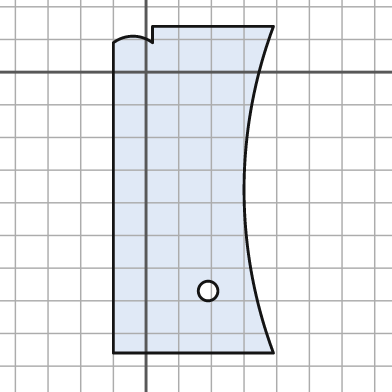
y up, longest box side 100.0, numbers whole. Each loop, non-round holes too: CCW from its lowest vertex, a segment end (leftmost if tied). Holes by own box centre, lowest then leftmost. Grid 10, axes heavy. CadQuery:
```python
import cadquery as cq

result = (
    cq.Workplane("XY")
    .moveTo(-10.0, -86.0)
    .lineTo(39.0, -86.0)
    .threePointArc((30.0, -36.0), (39.0, 14.0))
    .lineTo(2.0, 14.0)
    .lineTo(2.0, 9.0)
    .threePointArc((-4.0, 11.0), (-10.0, 9.0))
    .close()
    .moveTo(19.0, -67.0)
    .circle(3.0)
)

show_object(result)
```